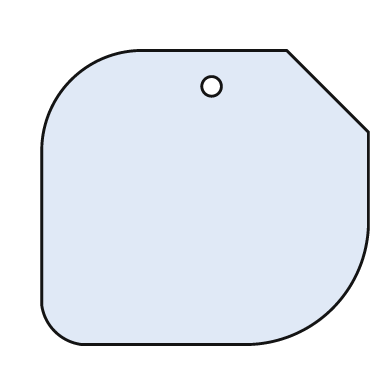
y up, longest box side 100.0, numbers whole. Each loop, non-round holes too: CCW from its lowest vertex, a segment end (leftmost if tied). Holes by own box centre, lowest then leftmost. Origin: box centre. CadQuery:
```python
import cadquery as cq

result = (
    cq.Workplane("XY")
    .moveTo(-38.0, -45.0)
    .lineTo(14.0, -45.0)
    .threePointArc((39.0, -34.0), (50.0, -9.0))
    .lineTo(50.0, 20.0)
    .lineTo(25.0, 45.0)
    .lineTo(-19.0, 45.0)
    .threePointArc((-41.0, 36.0), (-50.0, 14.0))
    .lineTo(-50.0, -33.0)
    .threePointArc((-46.0, -41.0), (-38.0, -45.0))
    .close()
    .moveTo(2.0, 34.0)
    .circle(3.0)
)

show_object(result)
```